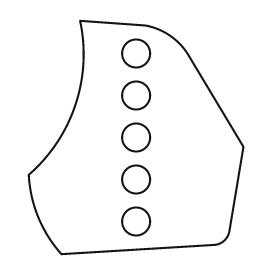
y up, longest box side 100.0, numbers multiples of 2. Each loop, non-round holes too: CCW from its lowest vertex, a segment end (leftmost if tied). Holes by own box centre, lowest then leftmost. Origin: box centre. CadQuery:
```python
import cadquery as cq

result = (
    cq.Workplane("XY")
    .moveTo(-32.0, -50.0)
    .lineTo(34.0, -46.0)
    .threePointArc((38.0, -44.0), (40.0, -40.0))
    .lineTo(46.0, -4.0)
    .lineTo(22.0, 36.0)
    .threePointArc((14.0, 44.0), (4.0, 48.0))
    .lineTo(-24.0, 50.0)
    .threePointArc((-26.0, 14.0), (-46.0, -16.0))
    .threePointArc((-42.0, -34.0), (-32.0, -50.0))
    .close()
    .moveTo(0.0, -36.0)
    .circle(6.0)
    .moveTo(0.0, -18.0)
    .circle(6.0)
    .moveTo(0.0, 0.0)
    .circle(6.0)
    .moveTo(0.0, 18.0)
    .circle(6.0)
    .moveTo(0.0, 36.0)
    .circle(6.0)
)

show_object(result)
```